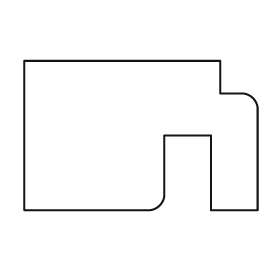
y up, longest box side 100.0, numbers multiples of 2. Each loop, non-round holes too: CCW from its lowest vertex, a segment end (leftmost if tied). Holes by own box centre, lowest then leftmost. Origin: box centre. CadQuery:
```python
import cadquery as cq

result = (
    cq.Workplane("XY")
    .moveTo(-50.0, -32.0)
    .lineTo(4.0, -32.0)
    .threePointArc((8.0, -30.0), (10.0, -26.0))
    .lineTo(10.0, 0.0)
    .lineTo(30.0, 0.0)
    .lineTo(30.0, -32.0)
    .lineTo(50.0, -32.0)
    .lineTo(50.0, 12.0)
    .threePointArc((48.0, 16.0), (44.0, 18.0))
    .lineTo(34.0, 18.0)
    .lineTo(34.0, 32.0)
    .lineTo(-50.0, 32.0)
    .close()
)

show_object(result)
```